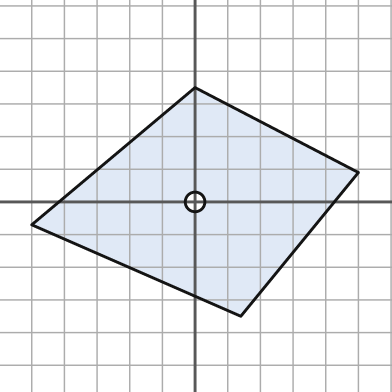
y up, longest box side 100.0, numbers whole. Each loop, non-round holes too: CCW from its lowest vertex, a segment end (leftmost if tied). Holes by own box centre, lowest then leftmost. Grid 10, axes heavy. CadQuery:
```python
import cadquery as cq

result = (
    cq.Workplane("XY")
    .moveTo(14.0, -35.0)
    .lineTo(50.0, 9.0)
    .lineTo(0.0, 35.0)
    .lineTo(-50.0, -7.0)
    .close()
    .moveTo(0.0, 0.0)
    .circle(3.0)
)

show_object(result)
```